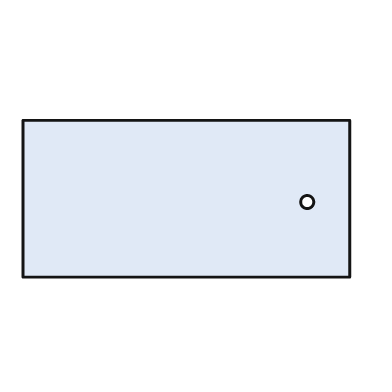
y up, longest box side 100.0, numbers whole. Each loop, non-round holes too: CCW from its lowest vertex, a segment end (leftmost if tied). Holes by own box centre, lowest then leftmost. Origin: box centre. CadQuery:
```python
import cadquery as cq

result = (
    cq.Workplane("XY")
    .moveTo(-50.0, -24.0)
    .lineTo(50.0, -24.0)
    .lineTo(50.0, 24.0)
    .lineTo(-50.0, 24.0)
    .close()
    .moveTo(37.0, -1.0)
    .circle(2.0)
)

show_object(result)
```